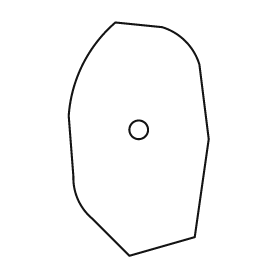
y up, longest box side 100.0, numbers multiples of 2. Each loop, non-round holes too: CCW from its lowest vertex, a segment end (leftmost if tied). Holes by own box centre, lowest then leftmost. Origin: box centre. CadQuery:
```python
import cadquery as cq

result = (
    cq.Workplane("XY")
    .moveTo(-4.0, -50.0)
    .lineTo(24.0, -42.0)
    .lineTo(30.0, 0.0)
    .lineTo(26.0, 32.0)
    .threePointArc((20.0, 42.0), (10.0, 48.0))
    .lineTo(-10.0, 50.0)
    .threePointArc((-24.0, 32.0), (-30.0, 10.0))
    .lineTo(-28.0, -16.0)
    .threePointArc((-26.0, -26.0), (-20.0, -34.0))
    .close()
    .moveTo(0.0, 4.0)
    .circle(4.0)
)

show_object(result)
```